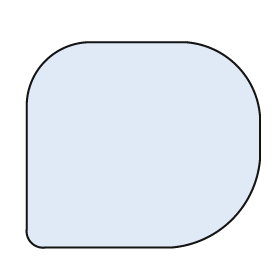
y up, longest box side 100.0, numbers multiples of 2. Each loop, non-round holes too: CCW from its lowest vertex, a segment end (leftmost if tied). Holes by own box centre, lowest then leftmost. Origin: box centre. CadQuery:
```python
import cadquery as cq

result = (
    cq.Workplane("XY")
    .moveTo(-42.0, -44.0)
    .lineTo(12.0, -44.0)
    .threePointArc((38.0, -32.0), (50.0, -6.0))
    .lineTo(50.0, 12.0)
    .threePointArc((40.0, 34.0), (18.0, 44.0))
    .lineTo(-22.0, 44.0)
    .threePointArc((-42.0, 36.0), (-50.0, 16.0))
    .lineTo(-50.0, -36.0)
    .threePointArc((-48.0, -42.0), (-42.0, -44.0))
    .close()
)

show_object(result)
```